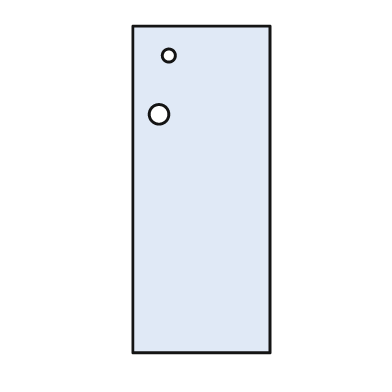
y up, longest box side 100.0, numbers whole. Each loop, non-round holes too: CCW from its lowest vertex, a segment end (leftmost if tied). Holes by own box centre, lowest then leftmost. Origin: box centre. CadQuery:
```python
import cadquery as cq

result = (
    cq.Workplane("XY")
    .moveTo(-21.0, -50.0)
    .lineTo(21.0, -50.0)
    .lineTo(21.0, 50.0)
    .lineTo(-21.0, 50.0)
    .close()
    .moveTo(-13.0, 23.0)
    .circle(3.0)
    .moveTo(-10.0, 41.0)
    .circle(2.0)
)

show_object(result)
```